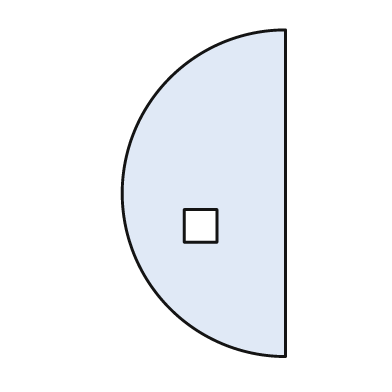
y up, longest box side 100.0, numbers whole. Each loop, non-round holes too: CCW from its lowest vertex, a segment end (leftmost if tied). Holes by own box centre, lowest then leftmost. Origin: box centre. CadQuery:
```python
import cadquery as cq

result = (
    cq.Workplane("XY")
    .moveTo(25.0, -50.0)
    .lineTo(25.0, 50.0)
    .threePointArc((-25.0, 0.0), (25.0, -50.0))
    .close()
    .moveTo(-6.0, -15.0)
    .lineTo(4.0, -15.0)
    .lineTo(4.0, -5.0)
    .lineTo(-6.0, -5.0)
    .close()
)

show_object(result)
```